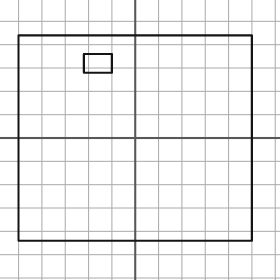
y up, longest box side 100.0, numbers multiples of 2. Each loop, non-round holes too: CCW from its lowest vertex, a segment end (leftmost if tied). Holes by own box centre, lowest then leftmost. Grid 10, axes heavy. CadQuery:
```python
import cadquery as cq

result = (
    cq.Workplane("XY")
    .moveTo(-50.0, -44.0)
    .lineTo(50.0, -44.0)
    .lineTo(50.0, 44.0)
    .lineTo(-50.0, 44.0)
    .close()
    .moveTo(-22.0, 28.0)
    .lineTo(-10.0, 28.0)
    .lineTo(-10.0, 36.0)
    .lineTo(-22.0, 36.0)
    .close()
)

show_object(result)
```